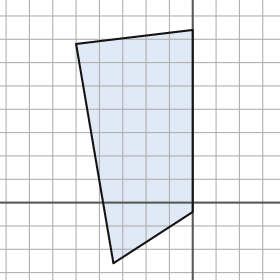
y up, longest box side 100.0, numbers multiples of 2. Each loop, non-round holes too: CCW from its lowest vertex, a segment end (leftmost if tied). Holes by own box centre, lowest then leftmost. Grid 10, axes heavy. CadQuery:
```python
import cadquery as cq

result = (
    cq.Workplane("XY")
    .moveTo(-34.0, -26.0)
    .lineTo(0.0, -4.0)
    .lineTo(0.0, 74.0)
    .lineTo(-50.0, 68.0)
    .close()
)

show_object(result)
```